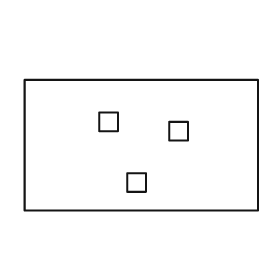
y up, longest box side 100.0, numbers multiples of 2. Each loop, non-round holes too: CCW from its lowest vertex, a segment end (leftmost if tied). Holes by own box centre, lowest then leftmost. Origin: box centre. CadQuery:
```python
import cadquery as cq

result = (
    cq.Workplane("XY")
    .moveTo(-50.0, -28.0)
    .lineTo(50.0, -28.0)
    .lineTo(50.0, 28.0)
    .lineTo(-50.0, 28.0)
    .close()
    .moveTo(-6.0, -20.0)
    .lineTo(2.0, -20.0)
    .lineTo(2.0, -12.0)
    .lineTo(-6.0, -12.0)
    .close()
    .moveTo(12.0, 2.0)
    .lineTo(20.0, 2.0)
    .lineTo(20.0, 10.0)
    .lineTo(12.0, 10.0)
    .close()
    .moveTo(-18.0, 6.0)
    .lineTo(-10.0, 6.0)
    .lineTo(-10.0, 14.0)
    .lineTo(-18.0, 14.0)
    .close()
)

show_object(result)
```